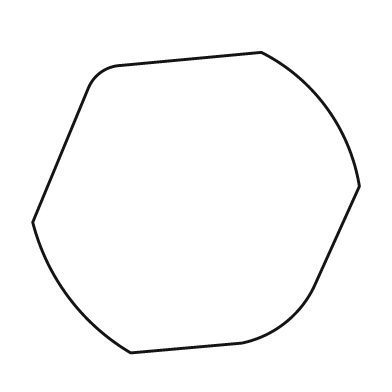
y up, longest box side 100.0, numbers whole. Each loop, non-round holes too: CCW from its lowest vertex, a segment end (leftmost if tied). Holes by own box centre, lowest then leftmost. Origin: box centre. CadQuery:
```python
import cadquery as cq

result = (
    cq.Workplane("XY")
    .moveTo(-20.0, -46.0)
    .lineTo(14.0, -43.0)
    .threePointArc((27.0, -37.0), (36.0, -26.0))
    .lineTo(50.0, 5.0)
    .threePointArc((40.0, 29.0), (20.0, 46.0))
    .lineTo(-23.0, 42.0)
    .threePointArc((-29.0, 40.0), (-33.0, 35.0))
    .lineTo(-50.0, -6.0)
    .threePointArc((-39.0, -29.0), (-20.0, -46.0))
    .close()
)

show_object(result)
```